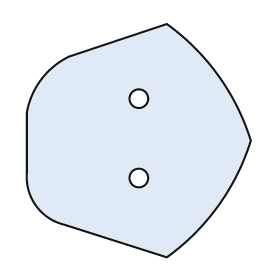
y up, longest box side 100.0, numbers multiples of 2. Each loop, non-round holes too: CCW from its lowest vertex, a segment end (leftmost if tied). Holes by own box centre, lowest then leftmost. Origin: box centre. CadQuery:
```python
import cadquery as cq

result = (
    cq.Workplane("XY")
    .moveTo(12.0, -50.0)
    .threePointArc((34.0, -28.0), (48.0, 0.0))
    .threePointArc((34.0, 28.0), (12.0, 50.0))
    .lineTo(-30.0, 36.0)
    .threePointArc((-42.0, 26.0), (-48.0, 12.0))
    .lineTo(-48.0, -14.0)
    .threePointArc((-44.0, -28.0), (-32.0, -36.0))
    .close()
    .moveTo(0.0, -16.0)
    .circle(4.0)
    .moveTo(0.0, 18.0)
    .circle(4.0)
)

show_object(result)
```